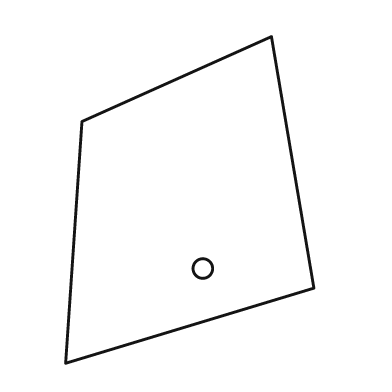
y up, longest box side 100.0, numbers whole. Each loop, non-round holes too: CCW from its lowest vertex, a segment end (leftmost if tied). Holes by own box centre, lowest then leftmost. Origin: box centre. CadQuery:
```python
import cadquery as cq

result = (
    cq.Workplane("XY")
    .moveTo(-38.0, -50.0)
    .lineTo(38.0, -27.0)
    .lineTo(25.0, 50.0)
    .lineTo(-33.0, 24.0)
    .close()
    .moveTo(4.0, -21.0)
    .circle(3.0)
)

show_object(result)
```